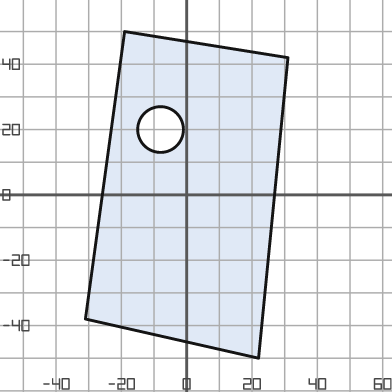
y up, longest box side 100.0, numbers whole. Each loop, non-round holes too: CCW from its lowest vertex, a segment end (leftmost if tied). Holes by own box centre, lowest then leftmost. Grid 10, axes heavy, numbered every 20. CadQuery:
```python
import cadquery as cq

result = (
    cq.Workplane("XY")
    .moveTo(22.0, -50.0)
    .lineTo(31.0, 42.0)
    .lineTo(-19.0, 50.0)
    .lineTo(-31.0, -38.0)
    .close()
    .moveTo(-8.0, 20.0)
    .circle(7.0)
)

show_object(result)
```